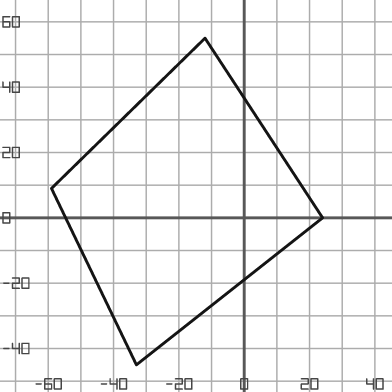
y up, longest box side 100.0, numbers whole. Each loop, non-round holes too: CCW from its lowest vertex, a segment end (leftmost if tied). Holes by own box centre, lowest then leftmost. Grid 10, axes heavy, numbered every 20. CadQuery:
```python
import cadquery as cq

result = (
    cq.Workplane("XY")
    .moveTo(-33.0, -45.0)
    .lineTo(24.0, 0.0)
    .lineTo(-12.0, 55.0)
    .lineTo(-59.0, 9.0)
    .close()
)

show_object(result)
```